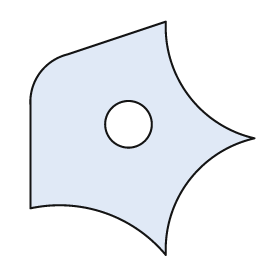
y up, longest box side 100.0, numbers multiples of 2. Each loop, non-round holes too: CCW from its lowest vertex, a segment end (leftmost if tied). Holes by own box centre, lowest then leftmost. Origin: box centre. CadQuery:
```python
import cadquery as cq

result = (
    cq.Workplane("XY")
    .moveTo(10.0, -50.0)
    .threePointArc((20.0, -18.0), (48.0, 0.0))
    .threePointArc((20.0, 18.0), (10.0, 50.0))
    .lineTo(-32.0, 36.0)
    .threePointArc((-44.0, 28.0), (-48.0, 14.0))
    .lineTo(-48.0, -30.0)
    .threePointArc((-16.0, -32.0), (10.0, -50.0))
    .close()
    .moveTo(-6.0, 6.0)
    .circle(10.0)
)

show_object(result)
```